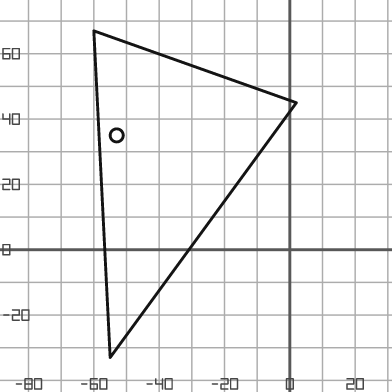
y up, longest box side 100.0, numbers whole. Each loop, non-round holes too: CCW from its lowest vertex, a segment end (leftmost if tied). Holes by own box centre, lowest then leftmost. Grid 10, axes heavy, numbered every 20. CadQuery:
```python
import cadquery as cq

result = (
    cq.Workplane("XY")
    .moveTo(-55.0, -33.0)
    .lineTo(2.0, 45.0)
    .lineTo(-60.0, 67.0)
    .close()
    .moveTo(-53.0, 35.0)
    .circle(2.0)
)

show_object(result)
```